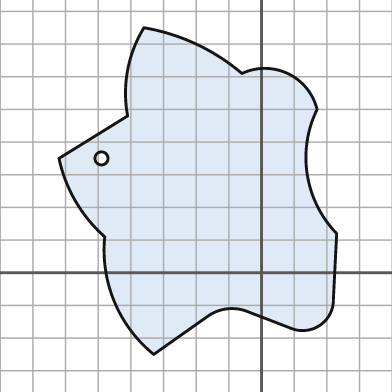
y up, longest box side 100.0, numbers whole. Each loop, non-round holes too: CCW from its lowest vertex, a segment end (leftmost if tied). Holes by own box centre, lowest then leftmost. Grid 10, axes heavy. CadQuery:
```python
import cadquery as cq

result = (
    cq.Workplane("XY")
    .moveTo(-33.0, -25.0)
    .lineTo(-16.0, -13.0)
    .threePointArc((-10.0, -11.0), (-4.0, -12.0))
    .lineTo(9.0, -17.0)
    .threePointArc((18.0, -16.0), (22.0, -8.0))
    .lineTo(23.0, 12.0)
    .threePointArc((14.0, 30.0), (17.0, 50.0))
    .threePointArc((8.0, 61.0), (-6.0, 61.0))
    .threePointArc((-20.0, 70.0), (-36.0, 75.0))
    .threePointArc((-41.0, 62.0), (-41.0, 48.0))
    .lineTo(-62.0, 35.0)
    .threePointArc((-57.0, 22.0), (-48.0, 11.0))
    .threePointArc((-45.0, -9.0), (-33.0, -25.0))
    .close()
    .moveTo(-49.0, 35.0)
    .circle(2.0)
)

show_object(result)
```